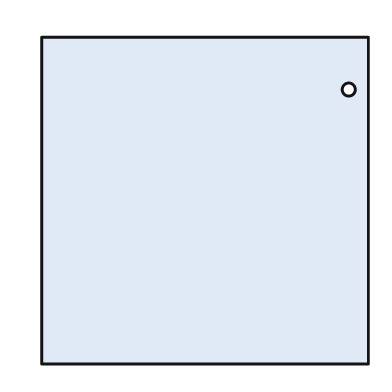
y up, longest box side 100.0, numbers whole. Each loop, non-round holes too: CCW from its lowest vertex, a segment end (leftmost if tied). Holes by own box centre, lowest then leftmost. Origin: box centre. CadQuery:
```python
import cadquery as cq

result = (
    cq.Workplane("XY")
    .moveTo(-50.0, -50.0)
    .lineTo(50.0, -50.0)
    .lineTo(50.0, 50.0)
    .lineTo(-50.0, 50.0)
    .close()
    .moveTo(44.0, 34.0)
    .circle(2.0)
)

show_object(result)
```